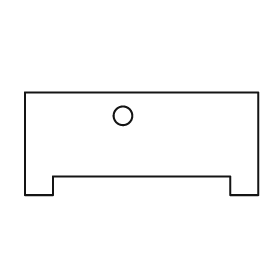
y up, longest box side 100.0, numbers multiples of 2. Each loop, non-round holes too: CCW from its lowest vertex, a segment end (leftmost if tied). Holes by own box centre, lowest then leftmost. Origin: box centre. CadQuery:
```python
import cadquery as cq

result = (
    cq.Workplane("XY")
    .moveTo(-50.0, -22.0)
    .lineTo(-38.0, -22.0)
    .lineTo(-38.0, -14.0)
    .lineTo(38.0, -14.0)
    .lineTo(38.0, -22.0)
    .lineTo(50.0, -22.0)
    .lineTo(50.0, 22.0)
    .lineTo(-50.0, 22.0)
    .close()
    .moveTo(-8.0, 12.0)
    .circle(4.0)
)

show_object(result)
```